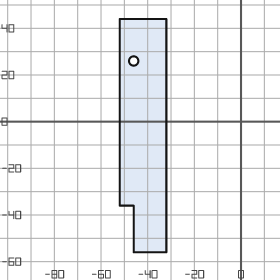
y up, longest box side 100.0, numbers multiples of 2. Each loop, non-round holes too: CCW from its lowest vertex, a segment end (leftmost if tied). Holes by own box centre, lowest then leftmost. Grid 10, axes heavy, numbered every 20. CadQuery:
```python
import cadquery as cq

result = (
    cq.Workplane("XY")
    .moveTo(-46.0, -56.0)
    .lineTo(-32.0, -56.0)
    .lineTo(-32.0, 44.0)
    .lineTo(-52.0, 44.0)
    .lineTo(-52.0, -36.0)
    .lineTo(-46.0, -36.0)
    .close()
    .moveTo(-46.0, 26.0)
    .circle(2.0)
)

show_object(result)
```